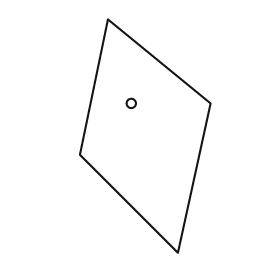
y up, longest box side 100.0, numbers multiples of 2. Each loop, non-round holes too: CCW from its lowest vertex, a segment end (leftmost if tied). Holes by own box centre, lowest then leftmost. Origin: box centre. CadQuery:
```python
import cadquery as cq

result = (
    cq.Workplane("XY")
    .moveTo(14.0, -50.0)
    .lineTo(28.0, 14.0)
    .lineTo(-16.0, 50.0)
    .lineTo(-28.0, -8.0)
    .close()
    .moveTo(-6.0, 14.0)
    .circle(2.0)
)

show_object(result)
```